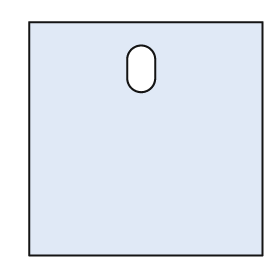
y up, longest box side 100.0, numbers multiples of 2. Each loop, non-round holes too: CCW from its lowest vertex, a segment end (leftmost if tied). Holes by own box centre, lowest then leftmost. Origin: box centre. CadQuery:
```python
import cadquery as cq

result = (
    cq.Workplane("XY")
    .moveTo(-50.0, -50.0)
    .lineTo(50.0, -50.0)
    .lineTo(50.0, 50.0)
    .lineTo(-50.0, 50.0)
    .close()
    .moveTo(-8.0, 26.0)
    .threePointArc((-2.0, 20.0), (4.0, 26.0))
    .lineTo(4.0, 34.0)
    .threePointArc((-2.0, 40.0), (-8.0, 34.0))
    .close()
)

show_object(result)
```